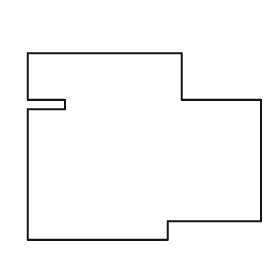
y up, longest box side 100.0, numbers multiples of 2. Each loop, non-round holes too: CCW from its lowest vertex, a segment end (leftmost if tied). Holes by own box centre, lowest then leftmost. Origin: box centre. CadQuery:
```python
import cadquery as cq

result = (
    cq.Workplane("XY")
    .moveTo(-50.0, -40.0)
    .lineTo(10.0, -40.0)
    .lineTo(10.0, -32.0)
    .lineTo(50.0, -32.0)
    .lineTo(50.0, 20.0)
    .lineTo(16.0, 20.0)
    .lineTo(16.0, 40.0)
    .lineTo(-50.0, 40.0)
    .lineTo(-50.0, 20.0)
    .lineTo(-34.0, 20.0)
    .lineTo(-34.0, 16.0)
    .lineTo(-50.0, 16.0)
    .close()
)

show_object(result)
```